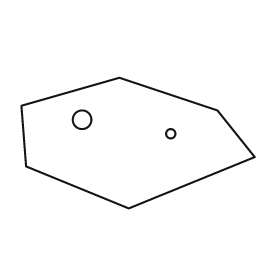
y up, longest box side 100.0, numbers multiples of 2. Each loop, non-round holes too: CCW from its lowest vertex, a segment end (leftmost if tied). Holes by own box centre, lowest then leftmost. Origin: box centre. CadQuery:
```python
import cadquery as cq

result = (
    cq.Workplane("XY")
    .moveTo(-4.0, -28.0)
    .lineTo(50.0, -6.0)
    .lineTo(34.0, 14.0)
    .lineTo(-8.0, 28.0)
    .lineTo(-50.0, 16.0)
    .lineTo(-48.0, -10.0)
    .close()
    .moveTo(14.0, 4.0)
    .circle(2.0)
    .moveTo(-24.0, 10.0)
    .circle(4.0)
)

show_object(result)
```